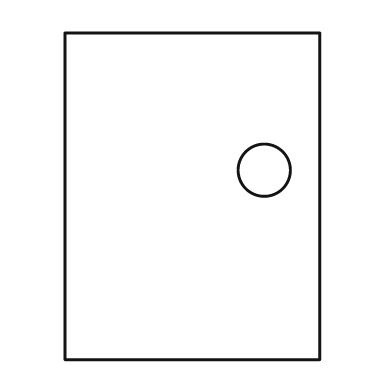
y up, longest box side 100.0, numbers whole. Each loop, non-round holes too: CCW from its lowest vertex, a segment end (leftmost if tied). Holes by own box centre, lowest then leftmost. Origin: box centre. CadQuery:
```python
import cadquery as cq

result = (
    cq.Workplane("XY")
    .moveTo(-39.0, -50.0)
    .lineTo(39.0, -50.0)
    .lineTo(39.0, 50.0)
    .lineTo(-39.0, 50.0)
    .close()
    .moveTo(22.0, 8.0)
    .circle(8.0)
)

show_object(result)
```